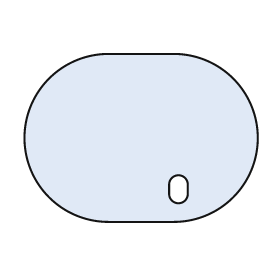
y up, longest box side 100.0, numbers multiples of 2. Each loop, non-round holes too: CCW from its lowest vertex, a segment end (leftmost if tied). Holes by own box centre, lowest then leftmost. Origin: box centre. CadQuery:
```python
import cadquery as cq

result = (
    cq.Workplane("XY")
    .moveTo(-14.0, -36.0)
    .lineTo(14.0, -36.0)
    .threePointArc((50.0, 0.0), (14.0, 36.0))
    .lineTo(-14.0, 36.0)
    .threePointArc((-50.0, 0.0), (-14.0, -36.0))
    .close()
    .moveTo(12.0, -24.0)
    .threePointArc((16.0, -28.0), (20.0, -24.0))
    .lineTo(20.0, -20.0)
    .threePointArc((16.0, -16.0), (12.0, -20.0))
    .close()
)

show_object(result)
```